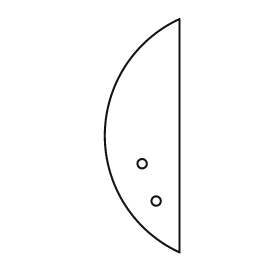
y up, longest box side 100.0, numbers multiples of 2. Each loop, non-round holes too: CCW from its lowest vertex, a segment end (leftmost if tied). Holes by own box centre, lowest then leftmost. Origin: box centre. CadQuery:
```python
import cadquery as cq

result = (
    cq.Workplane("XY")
    .moveTo(16.0, -50.0)
    .lineTo(16.0, 50.0)
    .threePointArc((-16.0, 0.0), (16.0, -50.0))
    .close()
    .moveTo(6.0, -28.0)
    .circle(2.0)
    .moveTo(0.0, -12.0)
    .circle(2.0)
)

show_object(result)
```